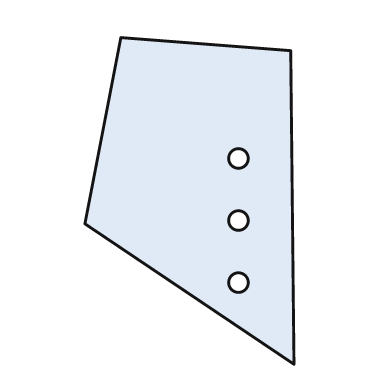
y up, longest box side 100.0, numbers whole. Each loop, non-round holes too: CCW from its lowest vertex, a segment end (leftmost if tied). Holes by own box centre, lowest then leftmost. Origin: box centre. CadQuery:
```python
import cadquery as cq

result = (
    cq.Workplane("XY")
    .moveTo(32.0, -50.0)
    .lineTo(31.0, 46.0)
    .lineTo(-21.0, 50.0)
    .lineTo(-32.0, -7.0)
    .close()
    .moveTo(15.0, -25.0)
    .circle(3.0)
    .moveTo(15.0, -6.0)
    .circle(3.0)
    .moveTo(15.0, 13.0)
    .circle(3.0)
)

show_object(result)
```